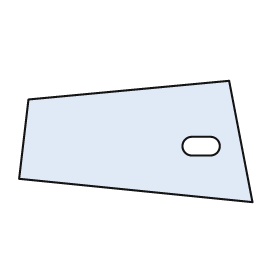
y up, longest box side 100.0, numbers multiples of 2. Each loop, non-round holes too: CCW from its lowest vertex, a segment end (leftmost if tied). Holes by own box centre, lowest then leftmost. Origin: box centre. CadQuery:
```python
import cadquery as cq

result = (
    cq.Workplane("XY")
    .moveTo(50.0, -26.0)
    .lineTo(40.0, 26.0)
    .lineTo(-46.0, 18.0)
    .lineTo(-50.0, -16.0)
    .close()
    .moveTo(24.0, -6.0)
    .lineTo(32.0, -6.0)
    .threePointArc((36.0, -2.0), (32.0, 2.0))
    .lineTo(24.0, 2.0)
    .threePointArc((20.0, -2.0), (24.0, -6.0))
    .close()
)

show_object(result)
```